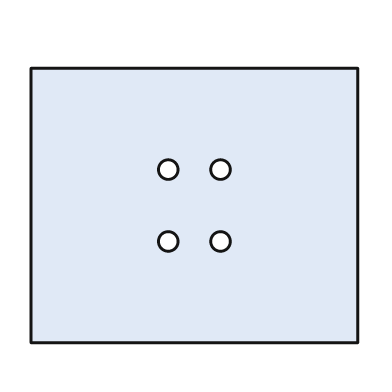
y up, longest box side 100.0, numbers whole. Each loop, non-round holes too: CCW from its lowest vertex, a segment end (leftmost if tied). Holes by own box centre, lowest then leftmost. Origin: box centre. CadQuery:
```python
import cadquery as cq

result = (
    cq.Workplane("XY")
    .moveTo(-50.0, -42.0)
    .lineTo(50.0, -42.0)
    .lineTo(50.0, 42.0)
    .lineTo(-50.0, 42.0)
    .close()
    .moveTo(-8.0, -11.0)
    .circle(3.0)
    .moveTo(8.0, -11.0)
    .circle(3.0)
    .moveTo(-8.0, 11.0)
    .circle(3.0)
    .moveTo(8.0, 11.0)
    .circle(3.0)
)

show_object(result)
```